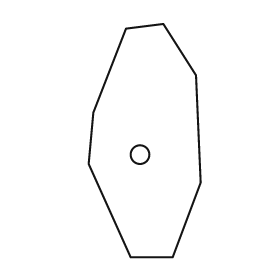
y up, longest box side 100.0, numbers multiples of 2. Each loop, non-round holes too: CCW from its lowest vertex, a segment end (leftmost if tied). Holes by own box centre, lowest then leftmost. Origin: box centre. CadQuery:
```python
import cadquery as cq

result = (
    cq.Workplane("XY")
    .moveTo(-6.0, -50.0)
    .lineTo(12.0, -50.0)
    .lineTo(24.0, -18.0)
    .lineTo(22.0, 28.0)
    .lineTo(8.0, 50.0)
    .lineTo(-8.0, 48.0)
    .lineTo(-22.0, 12.0)
    .lineTo(-24.0, -10.0)
    .close()
    .moveTo(-2.0, -6.0)
    .circle(4.0)
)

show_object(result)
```